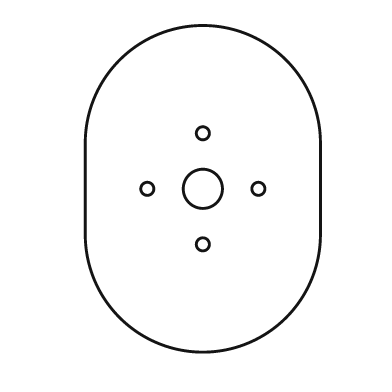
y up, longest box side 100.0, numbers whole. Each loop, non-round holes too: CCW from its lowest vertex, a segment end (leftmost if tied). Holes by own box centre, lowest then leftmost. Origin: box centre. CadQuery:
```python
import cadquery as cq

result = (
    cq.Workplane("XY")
    .moveTo(-36.0, -14.0)
    .threePointArc((0.0, -50.0), (36.0, -14.0))
    .lineTo(36.0, 14.0)
    .threePointArc((0.0, 50.0), (-36.0, 14.0))
    .close()
    .moveTo(0.0, -17.0)
    .circle(2.0)
    .moveTo(-17.0, 0.0)
    .circle(2.0)
    .moveTo(0.0, 0.0)
    .circle(6.0)
    .moveTo(17.0, 0.0)
    .circle(2.0)
    .moveTo(0.0, 17.0)
    .circle(2.0)
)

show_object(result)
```